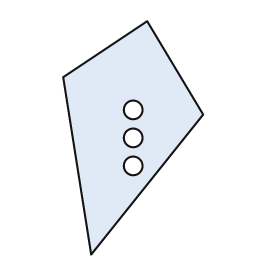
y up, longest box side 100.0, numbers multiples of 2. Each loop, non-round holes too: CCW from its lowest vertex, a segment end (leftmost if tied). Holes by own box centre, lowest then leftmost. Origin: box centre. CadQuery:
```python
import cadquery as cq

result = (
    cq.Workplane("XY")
    .moveTo(-18.0, -50.0)
    .lineTo(30.0, 10.0)
    .lineTo(6.0, 50.0)
    .lineTo(-30.0, 26.0)
    .close()
    .moveTo(0.0, -12.0)
    .circle(4.0)
    .moveTo(0.0, 0.0)
    .circle(4.0)
    .moveTo(0.0, 12.0)
    .circle(4.0)
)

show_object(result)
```